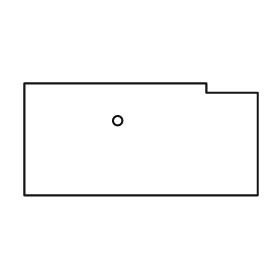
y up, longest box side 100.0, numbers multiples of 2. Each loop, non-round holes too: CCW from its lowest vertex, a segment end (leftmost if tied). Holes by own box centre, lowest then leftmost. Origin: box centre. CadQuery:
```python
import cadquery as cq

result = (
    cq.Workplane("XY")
    .moveTo(-50.0, -24.0)
    .lineTo(50.0, -24.0)
    .lineTo(50.0, 20.0)
    .lineTo(28.0, 20.0)
    .lineTo(28.0, 24.0)
    .lineTo(-50.0, 24.0)
    .close()
    .moveTo(-10.0, 8.0)
    .circle(2.0)
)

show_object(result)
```